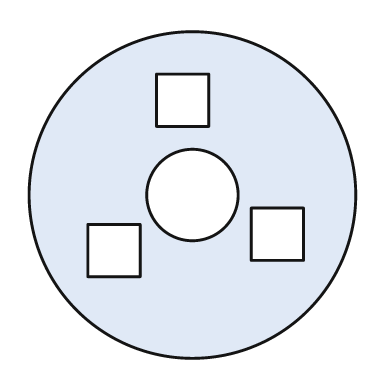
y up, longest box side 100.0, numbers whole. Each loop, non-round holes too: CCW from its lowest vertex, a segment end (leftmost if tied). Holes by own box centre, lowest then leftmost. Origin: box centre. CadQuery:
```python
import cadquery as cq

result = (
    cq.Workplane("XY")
    .moveTo(0.0, 0.0)
    .circle(50.0)
    .moveTo(-32.0, -25.0)
    .lineTo(-16.0, -25.0)
    .lineTo(-16.0, -9.0)
    .lineTo(-32.0, -9.0)
    .close()
    .moveTo(18.0, -20.0)
    .lineTo(34.0, -20.0)
    .lineTo(34.0, -4.0)
    .lineTo(18.0, -4.0)
    .close()
    .moveTo(0.0, 0.0)
    .circle(14.0)
    .moveTo(-11.0, 21.0)
    .lineTo(5.0, 21.0)
    .lineTo(5.0, 37.0)
    .lineTo(-11.0, 37.0)
    .close()
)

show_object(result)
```